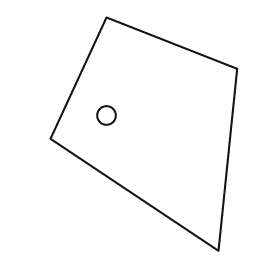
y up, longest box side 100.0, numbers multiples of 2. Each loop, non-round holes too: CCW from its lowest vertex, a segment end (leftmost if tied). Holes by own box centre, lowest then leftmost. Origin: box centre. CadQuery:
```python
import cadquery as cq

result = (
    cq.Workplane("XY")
    .moveTo(32.0, -50.0)
    .lineTo(40.0, 28.0)
    .lineTo(-16.0, 50.0)
    .lineTo(-40.0, -2.0)
    .close()
    .moveTo(-16.0, 8.0)
    .circle(4.0)
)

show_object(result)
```